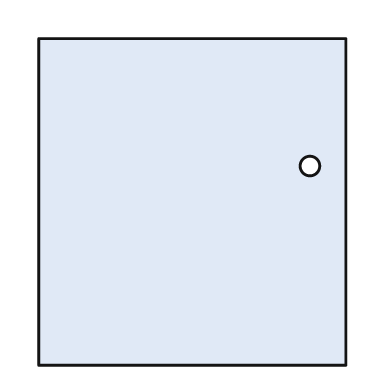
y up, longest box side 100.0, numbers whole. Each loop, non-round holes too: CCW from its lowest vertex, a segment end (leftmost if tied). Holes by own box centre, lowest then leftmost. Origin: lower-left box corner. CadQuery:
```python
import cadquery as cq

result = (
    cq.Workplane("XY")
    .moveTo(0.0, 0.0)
    .lineTo(94.0, 0.0)
    .lineTo(94.0, 100.0)
    .lineTo(0.0, 100.0)
    .close()
    .moveTo(83.0, 61.0)
    .circle(3.0)
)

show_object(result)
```